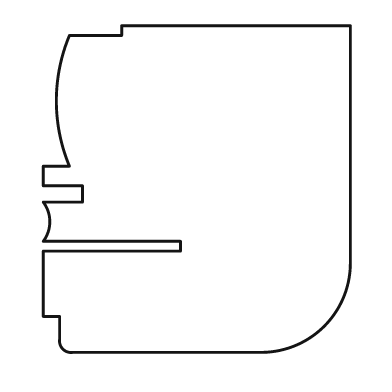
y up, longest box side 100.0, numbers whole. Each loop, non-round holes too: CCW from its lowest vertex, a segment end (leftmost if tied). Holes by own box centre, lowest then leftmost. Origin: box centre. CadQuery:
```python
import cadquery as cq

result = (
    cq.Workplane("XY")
    .moveTo(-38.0, -50.0)
    .lineTo(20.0, -50.0)
    .threePointArc((39.0, -42.0), (47.0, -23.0))
    .lineTo(47.0, 50.0)
    .lineTo(-23.0, 50.0)
    .lineTo(-23.0, 47.0)
    .lineTo(-39.0, 47.0)
    .threePointArc((-43.0, 27.0), (-39.0, 7.0))
    .lineTo(-47.0, 7.0)
    .lineTo(-47.0, 1.0)
    .lineTo(-35.0, 1.0)
    .lineTo(-35.0, -4.0)
    .lineTo(-47.0, -4.0)
    .threePointArc((-45.0, -10.0), (-47.0, -16.0))
    .lineTo(-5.0, -16.0)
    .lineTo(-5.0, -19.0)
    .lineTo(-47.0, -19.0)
    .lineTo(-47.0, -39.0)
    .lineTo(-42.0, -39.0)
    .lineTo(-42.0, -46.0)
    .threePointArc((-41.0, -49.0), (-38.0, -50.0))
    .close()
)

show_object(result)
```